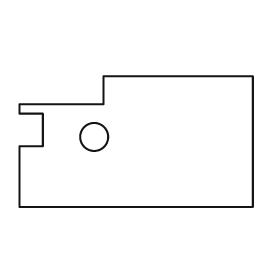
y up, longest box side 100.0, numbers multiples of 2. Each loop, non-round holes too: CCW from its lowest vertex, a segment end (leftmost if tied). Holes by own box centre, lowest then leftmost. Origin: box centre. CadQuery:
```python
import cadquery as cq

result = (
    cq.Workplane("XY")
    .moveTo(-50.0, -28.0)
    .lineTo(50.0, -28.0)
    .lineTo(50.0, 28.0)
    .lineTo(-14.0, 28.0)
    .lineTo(-14.0, 16.0)
    .lineTo(-50.0, 16.0)
    .lineTo(-50.0, 12.0)
    .lineTo(-40.0, 12.0)
    .lineTo(-40.0, -2.0)
    .lineTo(-50.0, -2.0)
    .close()
    .moveTo(-18.0, 2.0)
    .circle(6.0)
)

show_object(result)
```